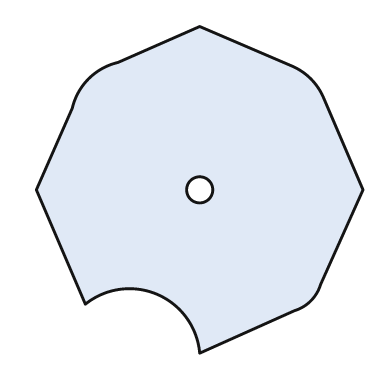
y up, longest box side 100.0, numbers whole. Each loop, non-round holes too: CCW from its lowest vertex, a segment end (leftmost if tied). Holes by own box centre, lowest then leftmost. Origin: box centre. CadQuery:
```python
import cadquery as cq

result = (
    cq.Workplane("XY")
    .moveTo(0.0, -50.0)
    .lineTo(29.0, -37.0)
    .threePointArc((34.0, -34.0), (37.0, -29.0))
    .lineTo(50.0, 0.0)
    .lineTo(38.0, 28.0)
    .threePointArc((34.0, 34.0), (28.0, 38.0))
    .lineTo(0.0, 50.0)
    .lineTo(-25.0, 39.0)
    .threePointArc((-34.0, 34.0), (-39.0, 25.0))
    .lineTo(-50.0, 0.0)
    .lineTo(-35.0, -35.0)
    .threePointArc((-13.0, -32.0), (0.0, -50.0))
    .close()
    .moveTo(0.0, 0.0)
    .circle(4.0)
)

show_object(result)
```